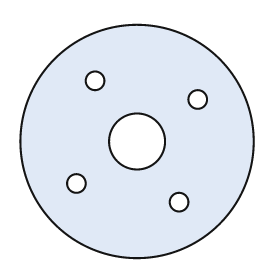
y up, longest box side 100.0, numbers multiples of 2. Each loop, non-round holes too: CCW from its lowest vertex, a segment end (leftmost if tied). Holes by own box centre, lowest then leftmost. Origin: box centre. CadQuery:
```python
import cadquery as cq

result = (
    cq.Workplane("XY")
    .moveTo(0.0, 0.0)
    .circle(50.0)
    .moveTo(18.0, -26.0)
    .circle(4.0)
    .moveTo(-26.0, -18.0)
    .circle(4.0)
    .moveTo(0.0, 0.0)
    .circle(12.0)
    .moveTo(26.0, 18.0)
    .circle(4.0)
    .moveTo(-18.0, 26.0)
    .circle(4.0)
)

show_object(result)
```